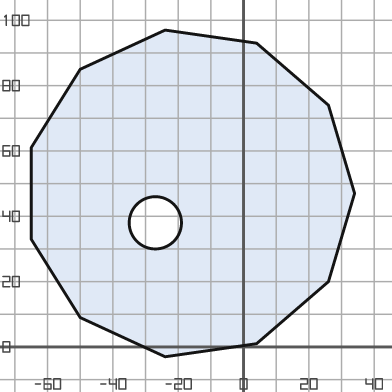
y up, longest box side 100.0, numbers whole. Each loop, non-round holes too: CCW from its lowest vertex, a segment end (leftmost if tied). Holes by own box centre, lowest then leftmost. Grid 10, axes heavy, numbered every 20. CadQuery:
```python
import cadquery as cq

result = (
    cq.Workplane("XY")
    .moveTo(-24.0, -3.0)
    .lineTo(4.0, 1.0)
    .lineTo(26.0, 20.0)
    .lineTo(34.0, 47.0)
    .lineTo(26.0, 74.0)
    .lineTo(4.0, 93.0)
    .lineTo(-24.0, 97.0)
    .lineTo(-50.0, 85.0)
    .lineTo(-65.0, 61.0)
    .lineTo(-65.0, 33.0)
    .lineTo(-50.0, 9.0)
    .close()
    .moveTo(-27.0, 38.0)
    .circle(8.0)
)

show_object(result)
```